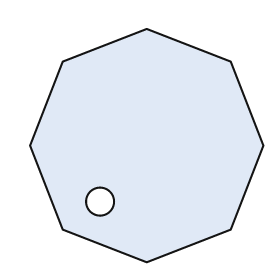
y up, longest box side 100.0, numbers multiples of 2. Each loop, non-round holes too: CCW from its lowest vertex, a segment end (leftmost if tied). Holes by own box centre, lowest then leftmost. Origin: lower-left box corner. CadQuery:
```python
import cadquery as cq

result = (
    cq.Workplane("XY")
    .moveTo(50.0, 0.0)
    .lineTo(86.0, 14.0)
    .lineTo(100.0, 50.0)
    .lineTo(86.0, 86.0)
    .lineTo(50.0, 100.0)
    .lineTo(14.0, 86.0)
    .lineTo(0.0, 50.0)
    .lineTo(14.0, 14.0)
    .close()
    .moveTo(30.0, 26.0)
    .circle(6.0)
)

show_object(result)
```